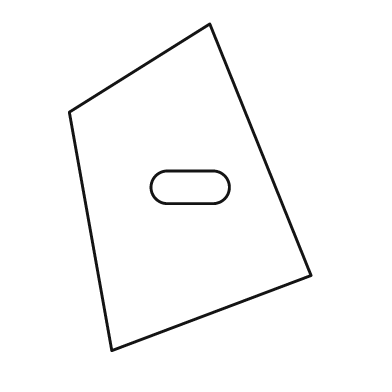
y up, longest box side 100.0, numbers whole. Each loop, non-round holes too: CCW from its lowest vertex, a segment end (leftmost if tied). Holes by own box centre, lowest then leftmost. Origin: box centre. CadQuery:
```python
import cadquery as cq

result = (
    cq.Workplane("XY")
    .moveTo(-24.0, -50.0)
    .lineTo(37.0, -27.0)
    .lineTo(6.0, 50.0)
    .lineTo(-37.0, 23.0)
    .close()
    .moveTo(-7.0, -5.0)
    .lineTo(7.0, -5.0)
    .threePointArc((12.0, 0.0), (7.0, 5.0))
    .lineTo(-7.0, 5.0)
    .threePointArc((-12.0, 0.0), (-7.0, -5.0))
    .close()
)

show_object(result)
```